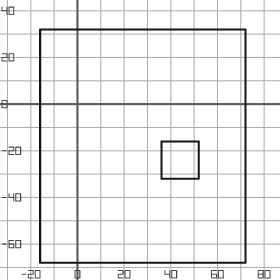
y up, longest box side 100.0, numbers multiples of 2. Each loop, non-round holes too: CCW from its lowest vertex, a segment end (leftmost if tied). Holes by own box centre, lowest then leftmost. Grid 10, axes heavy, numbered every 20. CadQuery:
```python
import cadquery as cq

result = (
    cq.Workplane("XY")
    .moveTo(-16.0, -68.0)
    .lineTo(72.0, -68.0)
    .lineTo(72.0, 32.0)
    .lineTo(-16.0, 32.0)
    .close()
    .moveTo(36.0, -32.0)
    .lineTo(52.0, -32.0)
    .lineTo(52.0, -16.0)
    .lineTo(36.0, -16.0)
    .close()
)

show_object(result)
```